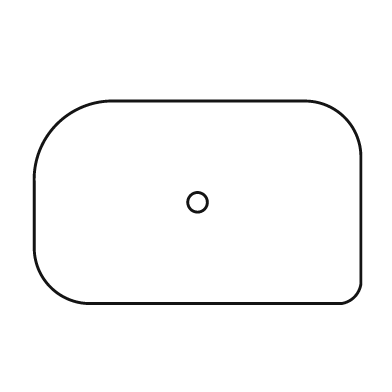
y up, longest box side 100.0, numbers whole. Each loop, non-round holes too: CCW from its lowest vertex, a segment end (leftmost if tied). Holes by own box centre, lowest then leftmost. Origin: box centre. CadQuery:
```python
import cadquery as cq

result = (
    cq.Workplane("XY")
    .moveTo(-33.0, -31.0)
    .lineTo(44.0, -31.0)
    .threePointArc((48.0, -29.0), (50.0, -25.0))
    .lineTo(50.0, 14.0)
    .threePointArc((45.0, 26.0), (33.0, 31.0))
    .lineTo(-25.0, 31.0)
    .threePointArc((-43.0, 24.0), (-50.0, 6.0))
    .lineTo(-50.0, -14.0)
    .threePointArc((-45.0, -26.0), (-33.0, -31.0))
    .close()
    .moveTo(0.0, 0.0)
    .circle(3.0)
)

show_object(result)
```